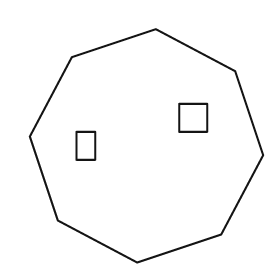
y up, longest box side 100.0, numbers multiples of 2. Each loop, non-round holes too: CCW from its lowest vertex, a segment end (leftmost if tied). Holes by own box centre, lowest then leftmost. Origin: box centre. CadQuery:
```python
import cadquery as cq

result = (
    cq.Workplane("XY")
    .moveTo(-4.0, -50.0)
    .lineTo(32.0, -38.0)
    .lineTo(50.0, -4.0)
    .lineTo(38.0, 32.0)
    .lineTo(4.0, 50.0)
    .lineTo(-32.0, 38.0)
    .lineTo(-50.0, 4.0)
    .lineTo(-38.0, -32.0)
    .close()
    .moveTo(-30.0, -6.0)
    .lineTo(-22.0, -6.0)
    .lineTo(-22.0, 6.0)
    .lineTo(-30.0, 6.0)
    .close()
    .moveTo(14.0, 6.0)
    .lineTo(26.0, 6.0)
    .lineTo(26.0, 18.0)
    .lineTo(14.0, 18.0)
    .close()
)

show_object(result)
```